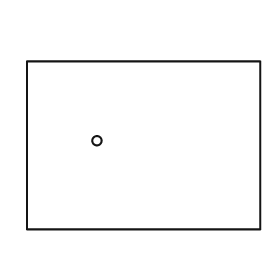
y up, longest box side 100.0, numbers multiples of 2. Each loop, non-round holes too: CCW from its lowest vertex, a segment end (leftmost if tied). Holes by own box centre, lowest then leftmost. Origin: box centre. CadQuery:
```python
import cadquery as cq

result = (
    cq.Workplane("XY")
    .moveTo(-50.0, -36.0)
    .lineTo(50.0, -36.0)
    .lineTo(50.0, 36.0)
    .lineTo(-50.0, 36.0)
    .close()
    .moveTo(-20.0, 2.0)
    .circle(2.0)
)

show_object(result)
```